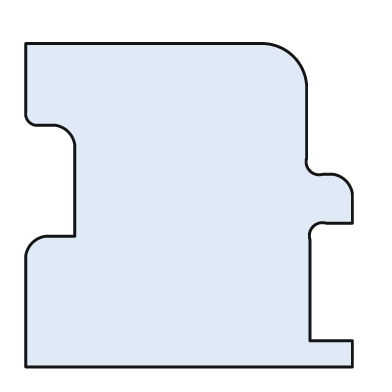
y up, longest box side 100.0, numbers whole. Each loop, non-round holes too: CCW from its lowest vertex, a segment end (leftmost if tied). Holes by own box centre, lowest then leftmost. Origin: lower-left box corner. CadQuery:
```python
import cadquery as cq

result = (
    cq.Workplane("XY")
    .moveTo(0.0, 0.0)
    .lineTo(100.0, 0.0)
    .lineTo(100.0, 8.0)
    .lineTo(87.0, 8.0)
    .lineTo(87.0, 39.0)
    .threePointArc((88.0, 43.0), (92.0, 44.0))
    .lineTo(100.0, 44.0)
    .lineTo(100.0, 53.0)
    .threePointArc((98.0, 57.0), (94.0, 59.0))
    .lineTo(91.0, 59.0)
    .threePointArc((87.0, 60.0), (86.0, 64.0))
    .lineTo(86.0, 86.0)
    .threePointArc((82.0, 95.0), (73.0, 99.0))
    .lineTo(0.0, 99.0)
    .lineTo(0.0, 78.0)
    .threePointArc((1.0, 75.0), (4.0, 74.0))
    .lineTo(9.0, 74.0)
    .threePointArc((13.0, 72.0), (15.0, 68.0))
    .lineTo(15.0, 40.0)
    .lineTo(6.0, 40.0)
    .threePointArc((2.0, 38.0), (0.0, 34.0))
    .close()
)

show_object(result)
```